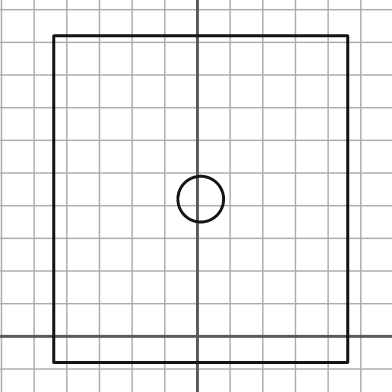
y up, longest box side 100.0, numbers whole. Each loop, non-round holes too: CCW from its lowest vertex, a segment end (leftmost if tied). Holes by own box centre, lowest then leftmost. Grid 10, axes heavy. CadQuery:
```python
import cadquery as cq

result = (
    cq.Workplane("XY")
    .moveTo(-44.0, -8.0)
    .lineTo(46.0, -8.0)
    .lineTo(46.0, 92.0)
    .lineTo(-44.0, 92.0)
    .close()
    .moveTo(1.0, 42.0)
    .circle(7.0)
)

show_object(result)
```